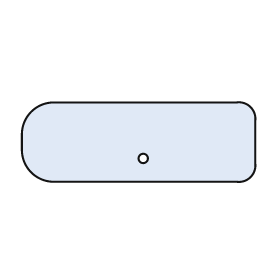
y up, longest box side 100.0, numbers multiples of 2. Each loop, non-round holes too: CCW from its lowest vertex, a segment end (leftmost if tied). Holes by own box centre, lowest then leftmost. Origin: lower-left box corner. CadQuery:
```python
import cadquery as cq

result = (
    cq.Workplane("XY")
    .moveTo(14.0, 0.0)
    .lineTo(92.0, 0.0)
    .threePointArc((98.0, 2.0), (100.0, 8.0))
    .lineTo(100.0, 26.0)
    .threePointArc((98.0, 32.0), (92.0, 34.0))
    .lineTo(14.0, 34.0)
    .threePointArc((4.0, 30.0), (0.0, 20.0))
    .lineTo(0.0, 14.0)
    .threePointArc((4.0, 4.0), (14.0, 0.0))
    .close()
    .moveTo(52.0, 10.0)
    .circle(2.0)
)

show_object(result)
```